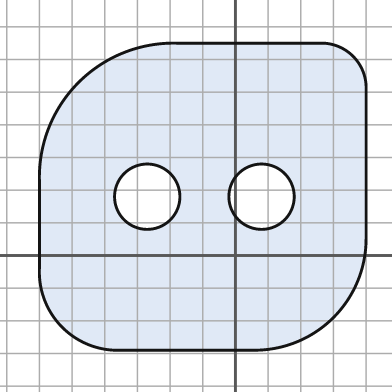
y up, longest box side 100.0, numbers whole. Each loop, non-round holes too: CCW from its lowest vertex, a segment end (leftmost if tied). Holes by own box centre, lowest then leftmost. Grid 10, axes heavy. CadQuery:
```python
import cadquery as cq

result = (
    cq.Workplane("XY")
    .moveTo(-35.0, -29.0)
    .lineTo(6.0, -29.0)
    .threePointArc((30.0, -19.0), (40.0, 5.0))
    .lineTo(40.0, 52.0)
    .threePointArc((36.0, 61.0), (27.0, 65.0))
    .lineTo(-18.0, 65.0)
    .threePointArc((-48.0, 53.0), (-60.0, 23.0))
    .lineTo(-60.0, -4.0)
    .threePointArc((-53.0, -22.0), (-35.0, -29.0))
    .close()
    .moveTo(-27.0, 18.0)
    .circle(10.0)
    .moveTo(8.0, 18.0)
    .circle(10.0)
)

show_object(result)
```